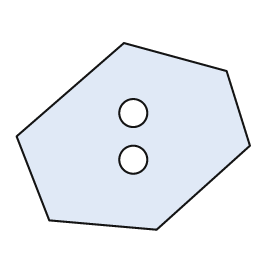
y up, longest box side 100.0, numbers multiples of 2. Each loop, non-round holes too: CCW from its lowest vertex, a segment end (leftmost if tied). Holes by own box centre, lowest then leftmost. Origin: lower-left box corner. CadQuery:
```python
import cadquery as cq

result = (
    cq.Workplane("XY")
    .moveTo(60.0, 0.0)
    .lineTo(100.0, 36.0)
    .lineTo(90.0, 68.0)
    .lineTo(46.0, 80.0)
    .lineTo(0.0, 40.0)
    .lineTo(14.0, 4.0)
    .close()
    .moveTo(50.0, 30.0)
    .circle(6.0)
    .moveTo(50.0, 50.0)
    .circle(6.0)
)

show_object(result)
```